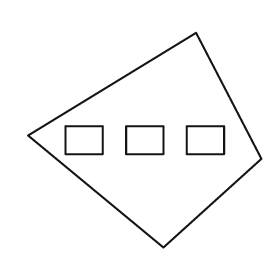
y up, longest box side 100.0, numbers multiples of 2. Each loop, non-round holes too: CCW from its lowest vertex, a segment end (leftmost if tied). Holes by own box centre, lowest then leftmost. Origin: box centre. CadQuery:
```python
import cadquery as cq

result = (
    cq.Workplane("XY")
    .moveTo(8.0, -46.0)
    .lineTo(50.0, -8.0)
    .lineTo(22.0, 46.0)
    .lineTo(-50.0, 2.0)
    .close()
    .moveTo(-34.0, -6.0)
    .lineTo(-18.0, -6.0)
    .lineTo(-18.0, 6.0)
    .lineTo(-34.0, 6.0)
    .close()
    .moveTo(-8.0, -6.0)
    .lineTo(8.0, -6.0)
    .lineTo(8.0, 6.0)
    .lineTo(-8.0, 6.0)
    .close()
    .moveTo(18.0, -6.0)
    .lineTo(34.0, -6.0)
    .lineTo(34.0, 6.0)
    .lineTo(18.0, 6.0)
    .close()
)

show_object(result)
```